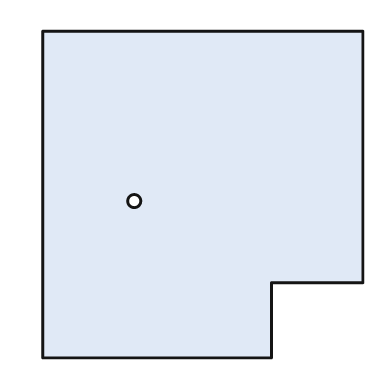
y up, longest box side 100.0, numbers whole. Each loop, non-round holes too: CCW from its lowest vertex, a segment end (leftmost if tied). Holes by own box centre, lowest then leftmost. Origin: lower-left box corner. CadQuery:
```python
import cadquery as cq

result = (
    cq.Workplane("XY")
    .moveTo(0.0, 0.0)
    .lineTo(70.0, 0.0)
    .lineTo(70.0, 23.0)
    .lineTo(98.0, 23.0)
    .lineTo(98.0, 100.0)
    .lineTo(0.0, 100.0)
    .close()
    .moveTo(28.0, 48.0)
    .circle(2.0)
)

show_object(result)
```